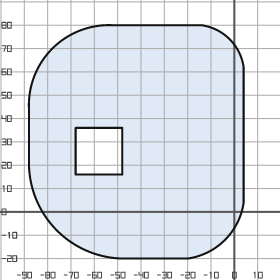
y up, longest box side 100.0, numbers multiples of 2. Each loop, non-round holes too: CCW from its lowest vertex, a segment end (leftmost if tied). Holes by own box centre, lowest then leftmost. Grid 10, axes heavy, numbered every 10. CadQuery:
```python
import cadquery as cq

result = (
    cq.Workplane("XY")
    .moveTo(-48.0, -20.0)
    .lineTo(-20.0, -20.0)
    .threePointArc((-4.0, -12.0), (4.0, 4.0))
    .lineTo(4.0, 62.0)
    .threePointArc((-2.0, 74.0), (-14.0, 80.0))
    .lineTo(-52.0, 80.0)
    .threePointArc((-78.0, 70.0), (-88.0, 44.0))
    .lineTo(-88.0, 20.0)
    .threePointArc((-76.0, -8.0), (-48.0, -20.0))
    .close()
    .moveTo(-68.0, 16.0)
    .lineTo(-48.0, 16.0)
    .lineTo(-48.0, 36.0)
    .lineTo(-68.0, 36.0)
    .close()
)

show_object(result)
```